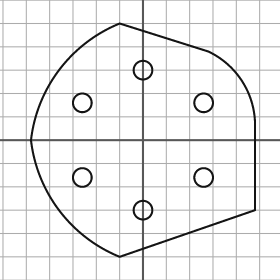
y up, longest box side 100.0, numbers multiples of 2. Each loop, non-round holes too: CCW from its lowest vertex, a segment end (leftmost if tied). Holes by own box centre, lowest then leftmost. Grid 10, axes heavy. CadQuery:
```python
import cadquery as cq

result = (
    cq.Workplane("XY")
    .moveTo(-10.0, -50.0)
    .lineTo(48.0, -30.0)
    .lineTo(48.0, 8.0)
    .threePointArc((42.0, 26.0), (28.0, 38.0))
    .lineTo(-10.0, 50.0)
    .threePointArc((-36.0, 30.0), (-48.0, 0.0))
    .threePointArc((-36.0, -30.0), (-10.0, -50.0))
    .close()
    .moveTo(0.0, -30.0)
    .circle(4.0)
    .moveTo(-26.0, -16.0)
    .circle(4.0)
    .moveTo(26.0, -16.0)
    .circle(4.0)
    .moveTo(-26.0, 16.0)
    .circle(4.0)
    .moveTo(26.0, 16.0)
    .circle(4.0)
    .moveTo(0.0, 30.0)
    .circle(4.0)
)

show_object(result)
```